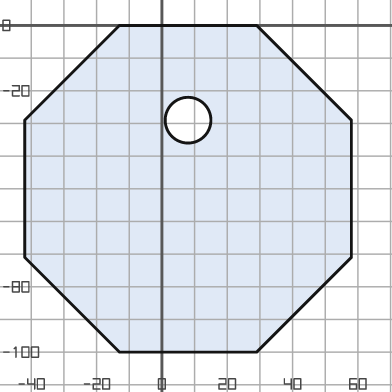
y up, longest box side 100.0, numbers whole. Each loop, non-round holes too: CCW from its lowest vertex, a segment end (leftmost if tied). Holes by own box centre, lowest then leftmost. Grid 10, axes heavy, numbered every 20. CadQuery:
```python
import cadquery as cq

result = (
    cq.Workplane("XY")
    .moveTo(-13.0, -100.0)
    .lineTo(29.0, -100.0)
    .lineTo(58.0, -71.0)
    .lineTo(58.0, -29.0)
    .lineTo(29.0, 0.0)
    .lineTo(-13.0, 0.0)
    .lineTo(-42.0, -29.0)
    .lineTo(-42.0, -71.0)
    .close()
    .moveTo(8.0, -29.0)
    .circle(7.0)
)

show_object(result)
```